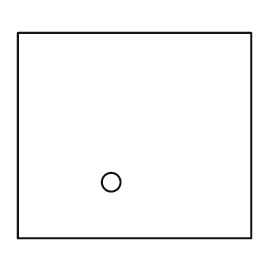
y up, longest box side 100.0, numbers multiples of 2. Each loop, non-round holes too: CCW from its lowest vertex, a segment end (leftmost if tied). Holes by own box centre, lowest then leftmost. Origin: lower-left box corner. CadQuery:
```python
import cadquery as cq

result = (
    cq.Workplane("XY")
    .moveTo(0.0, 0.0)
    .lineTo(100.0, 0.0)
    .lineTo(100.0, 88.0)
    .lineTo(0.0, 88.0)
    .close()
    .moveTo(40.0, 24.0)
    .circle(4.0)
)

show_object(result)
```